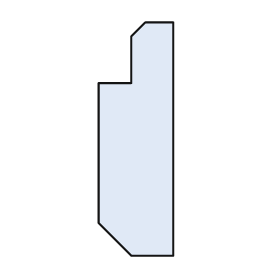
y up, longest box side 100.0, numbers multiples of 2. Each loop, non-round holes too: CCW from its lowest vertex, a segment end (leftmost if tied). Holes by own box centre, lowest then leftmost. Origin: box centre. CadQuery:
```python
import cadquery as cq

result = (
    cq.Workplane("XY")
    .moveTo(-2.0, -50.0)
    .lineTo(16.0, -50.0)
    .lineTo(16.0, 50.0)
    .lineTo(4.0, 50.0)
    .lineTo(-2.0, 44.0)
    .lineTo(-2.0, 24.0)
    .lineTo(-16.0, 24.0)
    .lineTo(-16.0, -36.0)
    .close()
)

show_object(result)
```